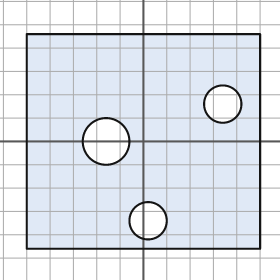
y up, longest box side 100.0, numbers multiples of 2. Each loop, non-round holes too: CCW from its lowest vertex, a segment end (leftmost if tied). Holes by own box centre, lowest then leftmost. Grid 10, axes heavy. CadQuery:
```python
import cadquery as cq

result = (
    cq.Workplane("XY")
    .moveTo(-50.0, -46.0)
    .lineTo(50.0, -46.0)
    .lineTo(50.0, 46.0)
    .lineTo(-50.0, 46.0)
    .close()
    .moveTo(2.0, -34.0)
    .circle(8.0)
    .moveTo(-16.0, 0.0)
    .circle(10.0)
    .moveTo(34.0, 16.0)
    .circle(8.0)
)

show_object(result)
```